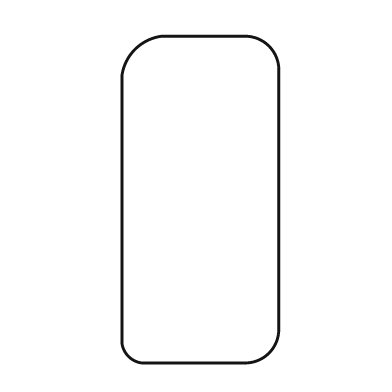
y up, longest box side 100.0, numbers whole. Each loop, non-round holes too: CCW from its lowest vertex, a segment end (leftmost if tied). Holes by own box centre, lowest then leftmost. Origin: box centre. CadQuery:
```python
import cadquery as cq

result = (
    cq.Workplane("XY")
    .moveTo(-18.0, -50.0)
    .lineTo(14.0, -50.0)
    .threePointArc((21.0, -47.0), (24.0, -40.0))
    .lineTo(24.0, 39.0)
    .threePointArc((21.0, 47.0), (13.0, 50.0))
    .lineTo(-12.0, 50.0)
    .threePointArc((-20.0, 46.0), (-24.0, 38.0))
    .lineTo(-24.0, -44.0)
    .threePointArc((-22.0, -48.0), (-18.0, -50.0))
    .close()
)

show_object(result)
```